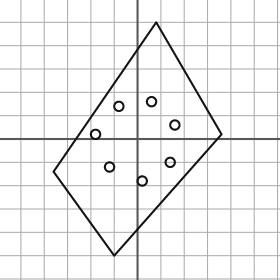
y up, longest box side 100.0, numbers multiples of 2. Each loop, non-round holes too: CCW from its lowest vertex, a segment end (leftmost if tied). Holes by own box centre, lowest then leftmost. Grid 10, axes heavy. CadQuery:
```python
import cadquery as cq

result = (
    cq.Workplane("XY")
    .moveTo(-10.0, -50.0)
    .lineTo(36.0, 2.0)
    .lineTo(8.0, 50.0)
    .lineTo(-36.0, -14.0)
    .close()
    .moveTo(2.0, -18.0)
    .circle(2.0)
    .moveTo(-12.0, -12.0)
    .circle(2.0)
    .moveTo(14.0, -10.0)
    .circle(2.0)
    .moveTo(-18.0, 2.0)
    .circle(2.0)
    .moveTo(16.0, 6.0)
    .circle(2.0)
    .moveTo(-8.0, 14.0)
    .circle(2.0)
    .moveTo(6.0, 16.0)
    .circle(2.0)
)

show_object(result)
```